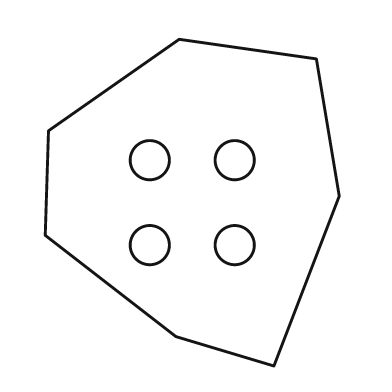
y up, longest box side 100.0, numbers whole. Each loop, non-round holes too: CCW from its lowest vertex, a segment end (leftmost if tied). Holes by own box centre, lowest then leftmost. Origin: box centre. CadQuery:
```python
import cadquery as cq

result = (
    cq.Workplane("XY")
    .moveTo(25.0, -50.0)
    .lineTo(45.0, 2.0)
    .lineTo(38.0, 44.0)
    .lineTo(-4.0, 50.0)
    .lineTo(-44.0, 22.0)
    .lineTo(-45.0, -10.0)
    .lineTo(-5.0, -41.0)
    .close()
    .moveTo(-13.0, -13.0)
    .circle(6.0)
    .moveTo(13.0, -13.0)
    .circle(6.0)
    .moveTo(-13.0, 13.0)
    .circle(6.0)
    .moveTo(13.0, 13.0)
    .circle(6.0)
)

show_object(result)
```